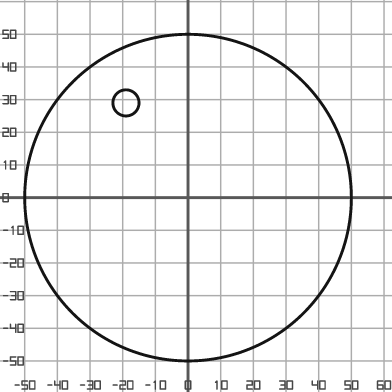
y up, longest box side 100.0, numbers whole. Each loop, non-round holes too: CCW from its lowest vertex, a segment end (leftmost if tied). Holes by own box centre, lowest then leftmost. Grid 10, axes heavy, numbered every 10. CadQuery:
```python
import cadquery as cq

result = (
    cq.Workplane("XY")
    .moveTo(0.0, 0.0)
    .circle(50.0)
    .moveTo(-19.0, 29.0)
    .circle(4.0)
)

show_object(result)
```